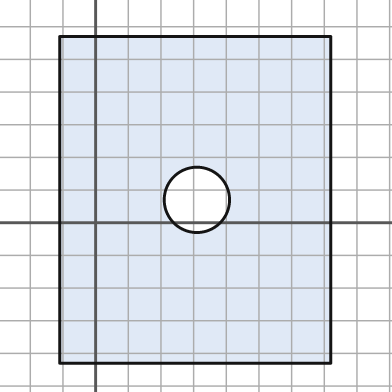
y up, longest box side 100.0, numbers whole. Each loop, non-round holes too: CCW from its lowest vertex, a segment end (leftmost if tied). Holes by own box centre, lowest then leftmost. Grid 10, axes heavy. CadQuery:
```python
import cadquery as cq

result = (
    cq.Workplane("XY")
    .moveTo(-11.0, -43.0)
    .lineTo(72.0, -43.0)
    .lineTo(72.0, 57.0)
    .lineTo(-11.0, 57.0)
    .close()
    .moveTo(31.0, 7.0)
    .circle(10.0)
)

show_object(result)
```